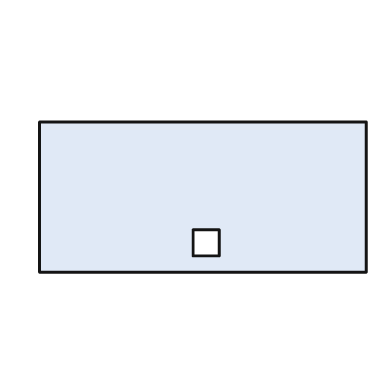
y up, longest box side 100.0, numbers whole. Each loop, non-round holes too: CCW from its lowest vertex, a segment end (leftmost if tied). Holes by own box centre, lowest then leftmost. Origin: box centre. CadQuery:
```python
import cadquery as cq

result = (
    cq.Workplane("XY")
    .moveTo(-50.0, -23.0)
    .lineTo(50.0, -23.0)
    .lineTo(50.0, 23.0)
    .lineTo(-50.0, 23.0)
    .close()
    .moveTo(-3.0, -18.0)
    .lineTo(5.0, -18.0)
    .lineTo(5.0, -10.0)
    .lineTo(-3.0, -10.0)
    .close()
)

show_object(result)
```